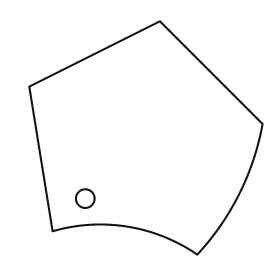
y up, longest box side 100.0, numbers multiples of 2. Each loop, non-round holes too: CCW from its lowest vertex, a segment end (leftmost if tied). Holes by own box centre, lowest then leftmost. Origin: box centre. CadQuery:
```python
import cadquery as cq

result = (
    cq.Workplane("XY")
    .moveTo(22.0, -50.0)
    .threePointArc((40.0, -24.0), (50.0, 6.0))
    .lineTo(6.0, 50.0)
    .lineTo(-50.0, 22.0)
    .lineTo(-40.0, -40.0)
    .threePointArc((-8.0, -38.0), (22.0, -50.0))
    .close()
    .moveTo(-26.0, -26.0)
    .circle(4.0)
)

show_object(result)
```